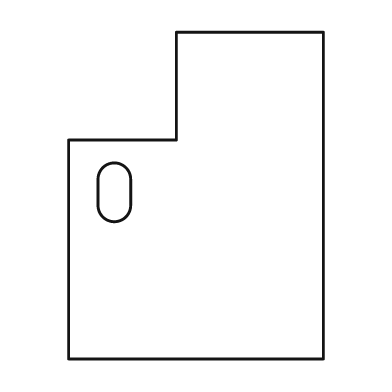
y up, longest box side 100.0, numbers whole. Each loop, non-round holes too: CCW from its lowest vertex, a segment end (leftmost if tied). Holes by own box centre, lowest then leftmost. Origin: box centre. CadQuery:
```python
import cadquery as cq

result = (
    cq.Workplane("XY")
    .moveTo(-39.0, -50.0)
    .lineTo(39.0, -50.0)
    .lineTo(39.0, 50.0)
    .lineTo(-6.0, 50.0)
    .lineTo(-6.0, 17.0)
    .lineTo(-39.0, 17.0)
    .close()
    .moveTo(-30.0, -3.0)
    .threePointArc((-25.0, -8.0), (-20.0, -3.0))
    .lineTo(-20.0, 5.0)
    .threePointArc((-25.0, 10.0), (-30.0, 5.0))
    .close()
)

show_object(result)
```